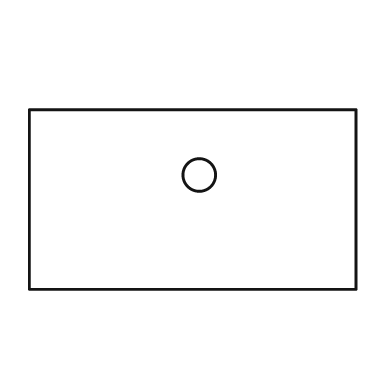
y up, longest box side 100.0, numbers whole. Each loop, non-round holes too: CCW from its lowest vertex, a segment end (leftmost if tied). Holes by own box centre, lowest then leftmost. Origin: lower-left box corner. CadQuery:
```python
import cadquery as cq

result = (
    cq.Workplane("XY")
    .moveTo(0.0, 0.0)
    .lineTo(100.0, 0.0)
    .lineTo(100.0, 55.0)
    .lineTo(0.0, 55.0)
    .close()
    .moveTo(52.0, 35.0)
    .circle(5.0)
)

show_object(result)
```